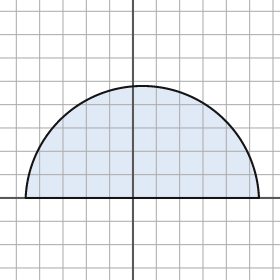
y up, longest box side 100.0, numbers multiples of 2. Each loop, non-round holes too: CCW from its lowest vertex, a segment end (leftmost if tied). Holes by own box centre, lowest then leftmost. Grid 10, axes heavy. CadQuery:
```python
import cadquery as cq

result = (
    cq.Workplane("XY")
    .moveTo(-46.0, 0.0)
    .lineTo(54.0, 0.0)
    .threePointArc((4.0, 48.0), (-46.0, 0.0))
    .close()
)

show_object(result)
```